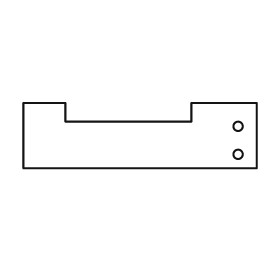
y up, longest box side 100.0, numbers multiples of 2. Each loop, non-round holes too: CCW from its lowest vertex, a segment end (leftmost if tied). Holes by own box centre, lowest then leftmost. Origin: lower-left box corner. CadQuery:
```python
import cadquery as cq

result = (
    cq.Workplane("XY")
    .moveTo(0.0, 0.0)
    .lineTo(100.0, 0.0)
    .lineTo(100.0, 28.0)
    .lineTo(72.0, 28.0)
    .lineTo(72.0, 20.0)
    .lineTo(18.0, 20.0)
    .lineTo(18.0, 28.0)
    .lineTo(0.0, 28.0)
    .close()
    .moveTo(92.0, 6.0)
    .circle(2.0)
    .moveTo(92.0, 18.0)
    .circle(2.0)
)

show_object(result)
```